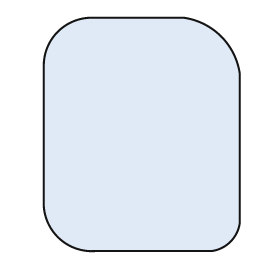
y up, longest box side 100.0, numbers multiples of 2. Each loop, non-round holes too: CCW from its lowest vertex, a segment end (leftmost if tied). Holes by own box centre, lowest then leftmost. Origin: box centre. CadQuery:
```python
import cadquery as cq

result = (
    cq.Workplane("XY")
    .moveTo(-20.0, -50.0)
    .lineTo(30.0, -50.0)
    .threePointArc((38.0, -46.0), (42.0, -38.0))
    .lineTo(42.0, 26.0)
    .threePointArc((34.0, 42.0), (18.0, 50.0))
    .lineTo(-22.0, 50.0)
    .threePointArc((-36.0, 44.0), (-42.0, 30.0))
    .lineTo(-42.0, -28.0)
    .threePointArc((-36.0, -44.0), (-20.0, -50.0))
    .close()
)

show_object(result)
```